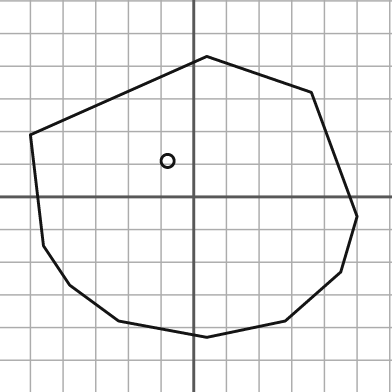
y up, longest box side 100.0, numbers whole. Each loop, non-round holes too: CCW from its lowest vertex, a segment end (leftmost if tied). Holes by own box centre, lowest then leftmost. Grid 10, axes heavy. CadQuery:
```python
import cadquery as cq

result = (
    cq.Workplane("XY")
    .moveTo(4.0, -43.0)
    .lineTo(28.0, -38.0)
    .lineTo(45.0, -23.0)
    .lineTo(50.0, -6.0)
    .lineTo(36.0, 32.0)
    .lineTo(4.0, 43.0)
    .lineTo(-50.0, 19.0)
    .lineTo(-46.0, -15.0)
    .lineTo(-38.0, -27.0)
    .lineTo(-23.0, -38.0)
    .close()
    .moveTo(-8.0, 11.0)
    .circle(2.0)
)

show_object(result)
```